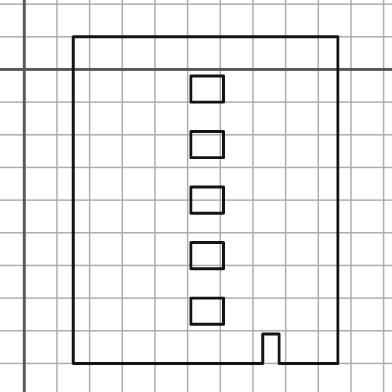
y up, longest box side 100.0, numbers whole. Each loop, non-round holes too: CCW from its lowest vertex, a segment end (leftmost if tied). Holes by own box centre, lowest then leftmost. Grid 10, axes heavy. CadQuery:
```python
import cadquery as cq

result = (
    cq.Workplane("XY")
    .moveTo(15.0, -90.0)
    .lineTo(73.0, -90.0)
    .lineTo(73.0, -81.0)
    .lineTo(78.0, -81.0)
    .lineTo(78.0, -90.0)
    .lineTo(96.0, -90.0)
    .lineTo(96.0, 10.0)
    .lineTo(15.0, 10.0)
    .close()
    .moveTo(51.0, -78.0)
    .lineTo(61.0, -78.0)
    .lineTo(61.0, -70.0)
    .lineTo(51.0, -70.0)
    .close()
    .moveTo(51.0, -61.0)
    .lineTo(61.0, -61.0)
    .lineTo(61.0, -53.0)
    .lineTo(51.0, -53.0)
    .close()
    .moveTo(51.0, -44.0)
    .lineTo(61.0, -44.0)
    .lineTo(61.0, -36.0)
    .lineTo(51.0, -36.0)
    .close()
    .moveTo(51.0, -27.0)
    .lineTo(61.0, -27.0)
    .lineTo(61.0, -19.0)
    .lineTo(51.0, -19.0)
    .close()
    .moveTo(51.0, -10.0)
    .lineTo(61.0, -10.0)
    .lineTo(61.0, -2.0)
    .lineTo(51.0, -2.0)
    .close()
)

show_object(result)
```